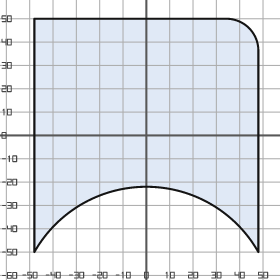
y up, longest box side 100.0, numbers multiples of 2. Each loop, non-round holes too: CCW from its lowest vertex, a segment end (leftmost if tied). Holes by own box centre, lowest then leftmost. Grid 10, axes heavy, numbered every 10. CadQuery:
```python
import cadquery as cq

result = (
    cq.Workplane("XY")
    .moveTo(-48.0, -50.0)
    .threePointArc((0.0, -22.0), (48.0, -50.0))
    .lineTo(48.0, 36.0)
    .threePointArc((44.0, 46.0), (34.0, 50.0))
    .lineTo(-48.0, 50.0)
    .close()
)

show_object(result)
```